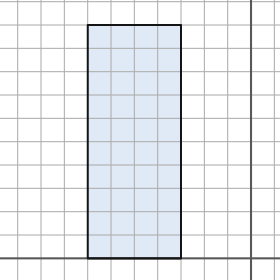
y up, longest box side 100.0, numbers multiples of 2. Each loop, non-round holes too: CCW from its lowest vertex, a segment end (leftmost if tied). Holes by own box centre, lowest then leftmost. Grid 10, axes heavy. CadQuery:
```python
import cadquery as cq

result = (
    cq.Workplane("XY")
    .moveTo(-70.0, 0.0)
    .lineTo(-30.0, 0.0)
    .lineTo(-30.0, 100.0)
    .lineTo(-70.0, 100.0)
    .close()
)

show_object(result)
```